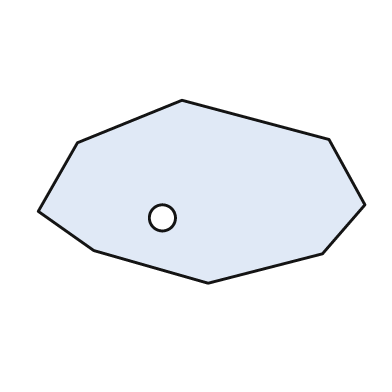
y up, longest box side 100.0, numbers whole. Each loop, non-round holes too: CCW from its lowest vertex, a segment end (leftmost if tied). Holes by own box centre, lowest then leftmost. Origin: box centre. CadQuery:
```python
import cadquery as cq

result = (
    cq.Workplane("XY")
    .moveTo(2.0, -28.0)
    .lineTo(37.0, -19.0)
    .lineTo(50.0, -4.0)
    .lineTo(39.0, 16.0)
    .lineTo(-6.0, 28.0)
    .lineTo(-38.0, 15.0)
    .lineTo(-50.0, -6.0)
    .lineTo(-33.0, -18.0)
    .close()
    .moveTo(-12.0, -8.0)
    .circle(4.0)
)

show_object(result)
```